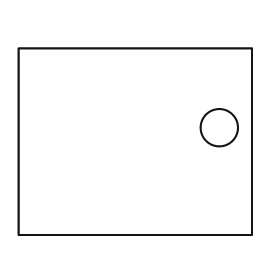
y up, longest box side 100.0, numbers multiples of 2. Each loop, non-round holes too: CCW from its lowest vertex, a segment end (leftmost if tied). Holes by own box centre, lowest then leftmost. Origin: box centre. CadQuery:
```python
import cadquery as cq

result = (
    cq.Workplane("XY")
    .moveTo(-50.0, -40.0)
    .lineTo(50.0, -40.0)
    .lineTo(50.0, 40.0)
    .lineTo(-50.0, 40.0)
    .close()
    .moveTo(36.0, 6.0)
    .circle(8.0)
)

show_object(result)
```